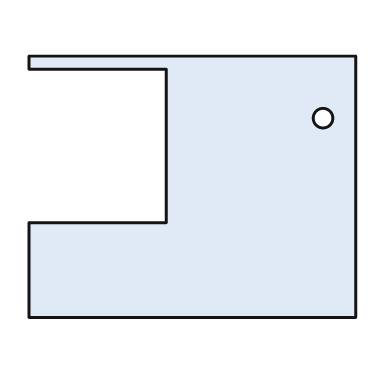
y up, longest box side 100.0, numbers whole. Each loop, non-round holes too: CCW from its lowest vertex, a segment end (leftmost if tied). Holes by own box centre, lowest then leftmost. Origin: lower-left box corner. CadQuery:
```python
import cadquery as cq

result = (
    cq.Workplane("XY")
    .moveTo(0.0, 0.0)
    .lineTo(100.0, 0.0)
    .lineTo(100.0, 80.0)
    .lineTo(0.0, 80.0)
    .lineTo(0.0, 76.0)
    .lineTo(42.0, 76.0)
    .lineTo(42.0, 29.0)
    .lineTo(0.0, 29.0)
    .close()
    .moveTo(90.0, 61.0)
    .circle(3.0)
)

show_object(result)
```